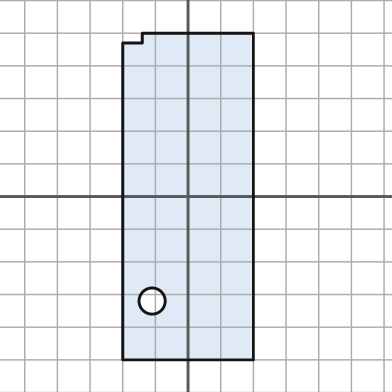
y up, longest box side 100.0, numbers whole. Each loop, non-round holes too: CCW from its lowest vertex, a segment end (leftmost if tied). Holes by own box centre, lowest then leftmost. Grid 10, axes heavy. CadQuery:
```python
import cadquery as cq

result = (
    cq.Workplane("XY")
    .moveTo(-20.0, -50.0)
    .lineTo(20.0, -50.0)
    .lineTo(20.0, 50.0)
    .lineTo(-14.0, 50.0)
    .lineTo(-14.0, 47.0)
    .lineTo(-20.0, 47.0)
    .close()
    .moveTo(-11.0, -32.0)
    .circle(4.0)
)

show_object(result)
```